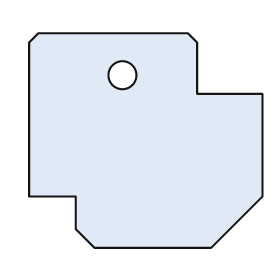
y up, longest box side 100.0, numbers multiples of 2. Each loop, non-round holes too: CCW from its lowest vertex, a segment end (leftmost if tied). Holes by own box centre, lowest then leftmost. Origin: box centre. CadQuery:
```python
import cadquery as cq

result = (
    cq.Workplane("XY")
    .moveTo(-22.0, -46.0)
    .lineTo(28.0, -46.0)
    .lineTo(50.0, -24.0)
    .lineTo(50.0, 20.0)
    .lineTo(22.0, 20.0)
    .lineTo(22.0, 42.0)
    .lineTo(18.0, 46.0)
    .lineTo(-46.0, 46.0)
    .lineTo(-50.0, 42.0)
    .lineTo(-50.0, -24.0)
    .lineTo(-30.0, -24.0)
    .lineTo(-30.0, -38.0)
    .close()
    .moveTo(-10.0, 28.0)
    .circle(6.0)
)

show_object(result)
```